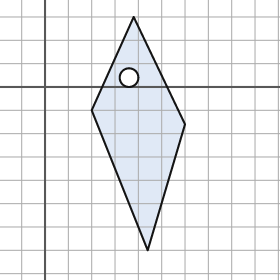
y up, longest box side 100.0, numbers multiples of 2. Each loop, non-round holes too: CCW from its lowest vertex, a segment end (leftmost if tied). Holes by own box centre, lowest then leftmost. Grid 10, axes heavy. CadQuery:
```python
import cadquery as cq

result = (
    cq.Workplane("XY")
    .moveTo(44.0, -70.0)
    .lineTo(60.0, -16.0)
    .lineTo(38.0, 30.0)
    .lineTo(20.0, -10.0)
    .close()
    .moveTo(36.0, 4.0)
    .circle(4.0)
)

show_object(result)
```